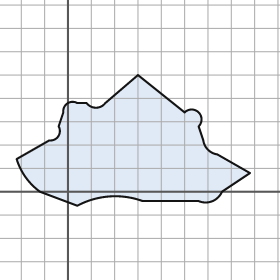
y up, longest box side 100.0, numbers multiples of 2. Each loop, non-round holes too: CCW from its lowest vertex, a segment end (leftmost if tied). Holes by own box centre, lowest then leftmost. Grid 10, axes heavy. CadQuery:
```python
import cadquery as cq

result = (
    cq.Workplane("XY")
    .moveTo(4.0, -6.0)
    .threePointArc((18.0, -2.0), (32.0, -4.0))
    .lineTo(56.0, -4.0)
    .threePointArc((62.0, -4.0), (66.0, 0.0))
    .lineTo(78.0, 8.0)
    .lineTo(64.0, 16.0)
    .threePointArc((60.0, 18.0), (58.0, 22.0))
    .lineTo(56.0, 28.0)
    .threePointArc((56.0, 34.0), (50.0, 34.0))
    .lineTo(30.0, 50.0)
    .lineTo(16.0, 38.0)
    .threePointArc((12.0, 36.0), (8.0, 38.0))
    .lineTo(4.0, 38.0)
    .threePointArc((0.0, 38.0), (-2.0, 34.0))
    .lineTo(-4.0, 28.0)
    .threePointArc((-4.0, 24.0), (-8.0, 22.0))
    .lineTo(-22.0, 14.0)
    .threePointArc((-18.0, 6.0), (-12.0, 0.0))
    .close()
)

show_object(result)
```